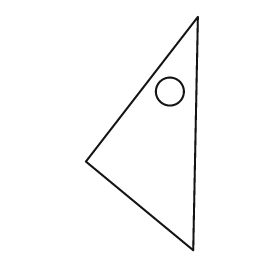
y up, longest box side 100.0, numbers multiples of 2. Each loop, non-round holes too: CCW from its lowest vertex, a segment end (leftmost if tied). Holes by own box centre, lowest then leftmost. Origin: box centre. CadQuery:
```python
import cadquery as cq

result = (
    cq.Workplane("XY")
    .moveTo(22.0, -50.0)
    .lineTo(24.0, 50.0)
    .lineTo(-24.0, -12.0)
    .close()
    .moveTo(12.0, 18.0)
    .circle(6.0)
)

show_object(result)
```